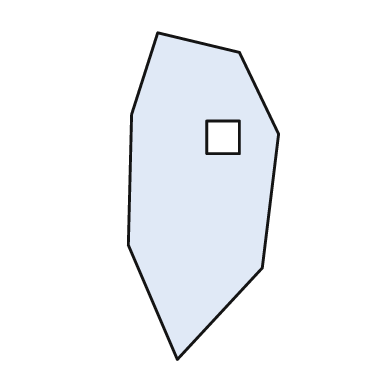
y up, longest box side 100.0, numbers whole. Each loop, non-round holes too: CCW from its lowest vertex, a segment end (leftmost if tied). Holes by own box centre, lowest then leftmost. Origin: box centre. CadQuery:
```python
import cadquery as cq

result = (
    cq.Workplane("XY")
    .moveTo(-8.0, -50.0)
    .lineTo(18.0, -22.0)
    .lineTo(23.0, 19.0)
    .lineTo(11.0, 44.0)
    .lineTo(-14.0, 50.0)
    .lineTo(-22.0, 25.0)
    .lineTo(-23.0, -15.0)
    .close()
    .moveTo(1.0, 13.0)
    .lineTo(11.0, 13.0)
    .lineTo(11.0, 23.0)
    .lineTo(1.0, 23.0)
    .close()
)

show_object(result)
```